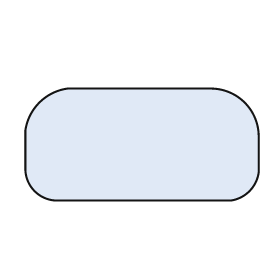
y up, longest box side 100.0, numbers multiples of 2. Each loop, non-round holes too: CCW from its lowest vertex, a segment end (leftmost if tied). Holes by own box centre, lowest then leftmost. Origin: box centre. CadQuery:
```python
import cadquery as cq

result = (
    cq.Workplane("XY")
    .moveTo(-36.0, -24.0)
    .lineTo(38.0, -24.0)
    .threePointArc((46.0, -20.0), (50.0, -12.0))
    .lineTo(50.0, 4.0)
    .threePointArc((44.0, 18.0), (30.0, 24.0))
    .lineTo(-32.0, 24.0)
    .threePointArc((-44.0, 18.0), (-50.0, 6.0))
    .lineTo(-50.0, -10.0)
    .threePointArc((-46.0, -20.0), (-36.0, -24.0))
    .close()
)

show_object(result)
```